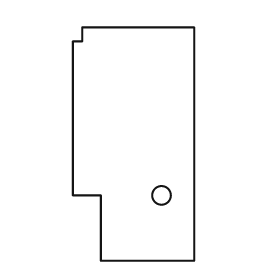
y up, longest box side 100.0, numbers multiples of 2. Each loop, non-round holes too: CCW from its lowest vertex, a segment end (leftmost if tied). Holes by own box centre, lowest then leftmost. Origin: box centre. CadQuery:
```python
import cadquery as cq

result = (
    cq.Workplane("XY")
    .moveTo(-14.0, -50.0)
    .lineTo(26.0, -50.0)
    .lineTo(26.0, 50.0)
    .lineTo(-22.0, 50.0)
    .lineTo(-22.0, 44.0)
    .lineTo(-26.0, 44.0)
    .lineTo(-26.0, -22.0)
    .lineTo(-14.0, -22.0)
    .close()
    .moveTo(12.0, -22.0)
    .circle(4.0)
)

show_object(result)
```